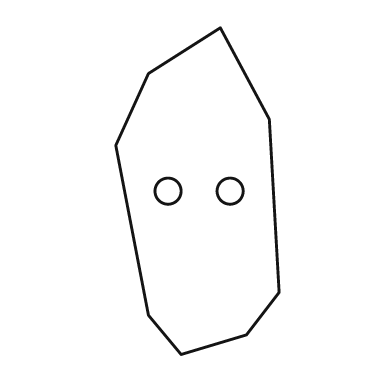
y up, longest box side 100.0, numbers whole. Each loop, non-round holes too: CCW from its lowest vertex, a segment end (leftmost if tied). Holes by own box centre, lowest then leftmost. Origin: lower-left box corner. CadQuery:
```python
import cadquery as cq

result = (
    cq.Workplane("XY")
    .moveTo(20.0, 0.0)
    .lineTo(40.0, 6.0)
    .lineTo(50.0, 19.0)
    .lineTo(47.0, 72.0)
    .lineTo(32.0, 100.0)
    .lineTo(10.0, 86.0)
    .lineTo(0.0, 64.0)
    .lineTo(10.0, 12.0)
    .close()
    .moveTo(16.0, 50.0)
    .circle(4.0)
    .moveTo(35.0, 50.0)
    .circle(4.0)
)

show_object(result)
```